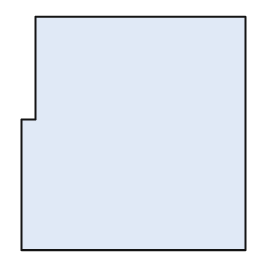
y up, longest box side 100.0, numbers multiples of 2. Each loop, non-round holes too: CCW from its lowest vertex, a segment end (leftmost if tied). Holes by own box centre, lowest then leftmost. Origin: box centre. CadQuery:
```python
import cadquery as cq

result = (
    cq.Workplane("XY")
    .moveTo(-48.0, -50.0)
    .lineTo(48.0, -50.0)
    .lineTo(48.0, 50.0)
    .lineTo(-42.0, 50.0)
    .lineTo(-42.0, 6.0)
    .lineTo(-48.0, 6.0)
    .close()
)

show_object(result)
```